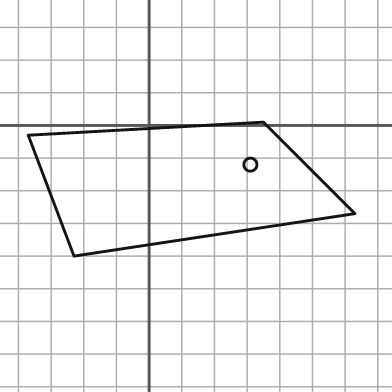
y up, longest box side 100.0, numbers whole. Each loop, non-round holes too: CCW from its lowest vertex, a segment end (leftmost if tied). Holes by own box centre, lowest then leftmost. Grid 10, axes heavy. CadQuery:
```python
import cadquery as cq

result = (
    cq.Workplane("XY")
    .moveTo(-23.0, -40.0)
    .lineTo(63.0, -27.0)
    .lineTo(35.0, 1.0)
    .lineTo(-37.0, -3.0)
    .close()
    .moveTo(31.0, -12.0)
    .circle(2.0)
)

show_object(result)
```